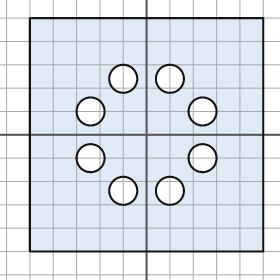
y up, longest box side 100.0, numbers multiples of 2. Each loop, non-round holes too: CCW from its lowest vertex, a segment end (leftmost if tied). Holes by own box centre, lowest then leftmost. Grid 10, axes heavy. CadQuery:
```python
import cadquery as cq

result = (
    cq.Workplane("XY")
    .moveTo(-50.0, -50.0)
    .lineTo(50.0, -50.0)
    .lineTo(50.0, 50.0)
    .lineTo(-50.0, 50.0)
    .close()
    .moveTo(-10.0, -24.0)
    .circle(6.0)
    .moveTo(10.0, -24.0)
    .circle(6.0)
    .moveTo(-24.0, -10.0)
    .circle(6.0)
    .moveTo(24.0, -10.0)
    .circle(6.0)
    .moveTo(-24.0, 10.0)
    .circle(6.0)
    .moveTo(24.0, 10.0)
    .circle(6.0)
    .moveTo(-10.0, 24.0)
    .circle(6.0)
    .moveTo(10.0, 24.0)
    .circle(6.0)
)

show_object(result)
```